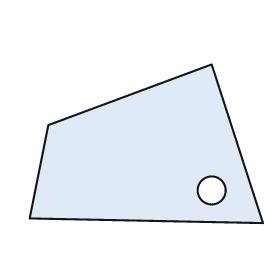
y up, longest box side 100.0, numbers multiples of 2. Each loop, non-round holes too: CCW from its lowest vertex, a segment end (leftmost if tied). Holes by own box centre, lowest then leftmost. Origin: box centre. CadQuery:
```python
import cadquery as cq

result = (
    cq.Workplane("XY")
    .moveTo(50.0, -34.0)
    .lineTo(28.0, 34.0)
    .lineTo(-42.0, 8.0)
    .lineTo(-50.0, -32.0)
    .close()
    .moveTo(28.0, -20.0)
    .circle(6.0)
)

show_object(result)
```